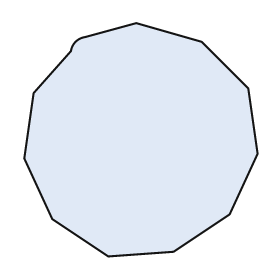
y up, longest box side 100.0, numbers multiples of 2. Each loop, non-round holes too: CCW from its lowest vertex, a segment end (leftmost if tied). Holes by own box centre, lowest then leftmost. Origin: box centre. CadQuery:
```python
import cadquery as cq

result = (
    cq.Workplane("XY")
    .moveTo(-14.0, -50.0)
    .lineTo(14.0, -48.0)
    .lineTo(38.0, -32.0)
    .lineTo(50.0, -6.0)
    .lineTo(46.0, 22.0)
    .lineTo(26.0, 42.0)
    .lineTo(-2.0, 50.0)
    .lineTo(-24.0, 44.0)
    .threePointArc((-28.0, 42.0), (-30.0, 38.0))
    .lineTo(-46.0, 20.0)
    .lineTo(-50.0, -8.0)
    .lineTo(-38.0, -34.0)
    .close()
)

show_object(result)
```